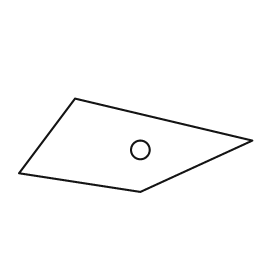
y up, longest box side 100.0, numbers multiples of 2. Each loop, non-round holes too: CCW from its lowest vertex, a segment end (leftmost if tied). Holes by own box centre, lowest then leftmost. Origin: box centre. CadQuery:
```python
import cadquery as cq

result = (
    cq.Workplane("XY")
    .moveTo(2.0, -20.0)
    .lineTo(50.0, 2.0)
    .lineTo(-26.0, 20.0)
    .lineTo(-50.0, -12.0)
    .close()
    .moveTo(2.0, -2.0)
    .circle(4.0)
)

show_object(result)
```